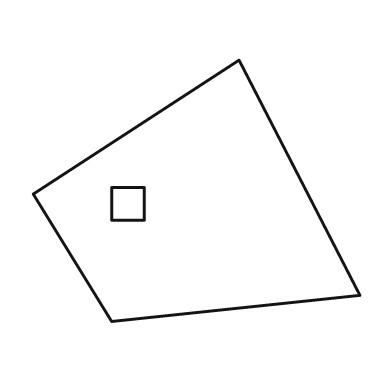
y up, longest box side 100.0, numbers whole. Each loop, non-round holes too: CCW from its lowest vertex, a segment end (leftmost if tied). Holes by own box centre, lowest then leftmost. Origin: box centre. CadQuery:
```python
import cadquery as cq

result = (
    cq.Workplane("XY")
    .moveTo(-26.0, -40.0)
    .lineTo(50.0, -32.0)
    .lineTo(13.0, 40.0)
    .lineTo(-50.0, -1.0)
    .close()
    .moveTo(-26.0, -9.0)
    .lineTo(-16.0, -9.0)
    .lineTo(-16.0, 1.0)
    .lineTo(-26.0, 1.0)
    .close()
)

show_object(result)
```